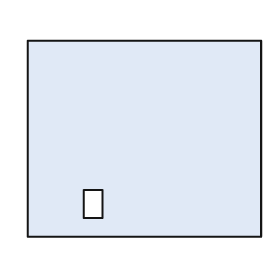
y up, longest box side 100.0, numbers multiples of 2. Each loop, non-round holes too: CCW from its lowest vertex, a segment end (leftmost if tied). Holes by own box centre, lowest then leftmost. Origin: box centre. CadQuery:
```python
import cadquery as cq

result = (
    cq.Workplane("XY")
    .moveTo(-50.0, -42.0)
    .lineTo(50.0, -42.0)
    .lineTo(50.0, 42.0)
    .lineTo(-50.0, 42.0)
    .close()
    .moveTo(-26.0, -34.0)
    .lineTo(-18.0, -34.0)
    .lineTo(-18.0, -22.0)
    .lineTo(-26.0, -22.0)
    .close()
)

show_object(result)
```